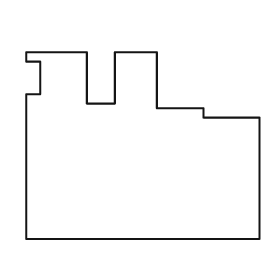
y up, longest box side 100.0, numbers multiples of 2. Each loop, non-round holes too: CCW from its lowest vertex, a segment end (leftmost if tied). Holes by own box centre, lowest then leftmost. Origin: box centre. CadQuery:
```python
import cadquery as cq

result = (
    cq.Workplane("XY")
    .moveTo(-50.0, -40.0)
    .lineTo(50.0, -40.0)
    .lineTo(50.0, 12.0)
    .lineTo(26.0, 12.0)
    .lineTo(26.0, 16.0)
    .lineTo(6.0, 16.0)
    .lineTo(6.0, 40.0)
    .lineTo(-12.0, 40.0)
    .lineTo(-12.0, 18.0)
    .lineTo(-24.0, 18.0)
    .lineTo(-24.0, 40.0)
    .lineTo(-50.0, 40.0)
    .lineTo(-50.0, 36.0)
    .lineTo(-44.0, 36.0)
    .lineTo(-44.0, 22.0)
    .lineTo(-50.0, 22.0)
    .close()
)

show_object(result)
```